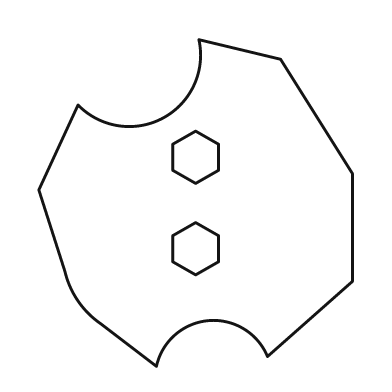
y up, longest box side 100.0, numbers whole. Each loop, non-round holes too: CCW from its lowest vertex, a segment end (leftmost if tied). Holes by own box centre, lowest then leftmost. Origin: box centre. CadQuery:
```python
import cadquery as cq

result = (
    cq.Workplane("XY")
    .moveTo(-12.0, -50.0)
    .threePointArc((4.0, -36.0), (22.0, -47.0))
    .lineTo(48.0, -24.0)
    .lineTo(48.0, 9.0)
    .lineTo(26.0, 44.0)
    .lineTo(1.0, 50.0)
    .threePointArc((-10.0, 26.0), (-36.0, 30.0))
    .lineTo(-48.0, 4.0)
    .lineTo(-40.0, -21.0)
    .threePointArc((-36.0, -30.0), (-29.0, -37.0))
    .close()
    .moveTo(0.0, -22.0)
    .lineTo(7.0, -18.0)
    .lineTo(7.0, -10.0)
    .lineTo(0.0, -6.0)
    .lineTo(-7.0, -10.0)
    .lineTo(-7.0, -18.0)
    .close()
    .moveTo(0.0, 6.0)
    .lineTo(7.0, 10.0)
    .lineTo(7.0, 18.0)
    .lineTo(0.0, 22.0)
    .lineTo(-7.0, 18.0)
    .lineTo(-7.0, 10.0)
    .close()
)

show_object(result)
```